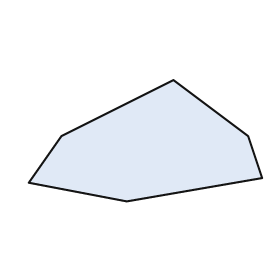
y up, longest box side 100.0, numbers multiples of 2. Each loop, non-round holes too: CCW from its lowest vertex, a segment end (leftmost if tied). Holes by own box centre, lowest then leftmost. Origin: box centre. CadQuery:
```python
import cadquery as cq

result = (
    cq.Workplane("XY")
    .moveTo(-8.0, -26.0)
    .lineTo(50.0, -16.0)
    .lineTo(44.0, 2.0)
    .lineTo(12.0, 26.0)
    .lineTo(-36.0, 2.0)
    .lineTo(-50.0, -18.0)
    .close()
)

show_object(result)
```